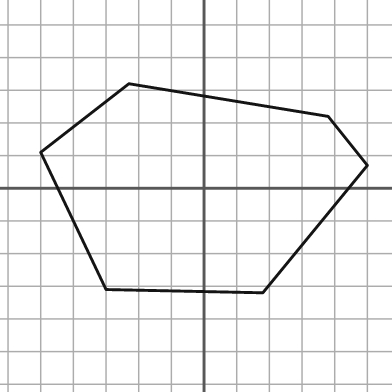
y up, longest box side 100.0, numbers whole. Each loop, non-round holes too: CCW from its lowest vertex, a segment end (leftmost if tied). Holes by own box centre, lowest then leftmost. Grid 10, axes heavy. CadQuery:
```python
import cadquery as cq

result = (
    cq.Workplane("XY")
    .moveTo(18.0, -32.0)
    .lineTo(50.0, 7.0)
    .lineTo(38.0, 22.0)
    .lineTo(-23.0, 32.0)
    .lineTo(-50.0, 11.0)
    .lineTo(-30.0, -31.0)
    .close()
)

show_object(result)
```